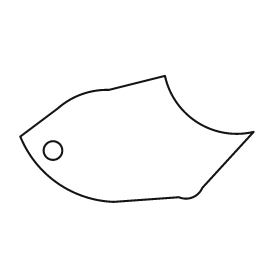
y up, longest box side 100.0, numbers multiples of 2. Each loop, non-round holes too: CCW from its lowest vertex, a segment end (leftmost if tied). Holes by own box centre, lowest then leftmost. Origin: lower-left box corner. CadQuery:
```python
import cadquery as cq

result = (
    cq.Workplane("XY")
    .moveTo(40.0, 0.0)
    .lineTo(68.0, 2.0)
    .threePointArc((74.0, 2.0), (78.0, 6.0))
    .lineTo(100.0, 30.0)
    .threePointArc((76.0, 34.0), (62.0, 54.0))
    .lineTo(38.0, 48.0)
    .threePointArc((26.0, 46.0), (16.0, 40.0))
    .lineTo(0.0, 28.0)
    .threePointArc((16.0, 8.0), (40.0, 0.0))
    .close()
    .moveTo(14.0, 22.0)
    .circle(4.0)
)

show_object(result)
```